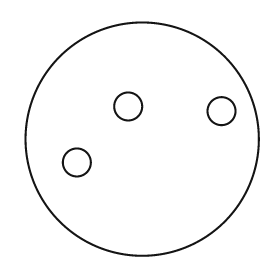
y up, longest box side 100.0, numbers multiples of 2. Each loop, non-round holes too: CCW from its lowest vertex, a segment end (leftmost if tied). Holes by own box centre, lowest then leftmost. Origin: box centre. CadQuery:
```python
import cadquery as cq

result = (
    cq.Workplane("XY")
    .moveTo(0.0, 0.0)
    .circle(50.0)
    .moveTo(-28.0, -10.0)
    .circle(6.0)
    .moveTo(34.0, 12.0)
    .circle(6.0)
    .moveTo(-6.0, 14.0)
    .circle(6.0)
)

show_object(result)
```